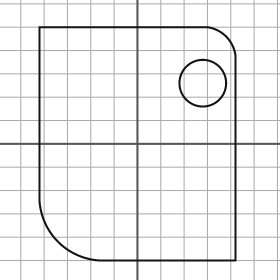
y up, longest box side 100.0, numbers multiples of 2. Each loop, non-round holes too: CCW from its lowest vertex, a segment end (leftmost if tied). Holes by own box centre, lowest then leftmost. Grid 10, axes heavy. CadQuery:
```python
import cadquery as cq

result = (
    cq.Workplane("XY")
    .moveTo(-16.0, -50.0)
    .lineTo(42.0, -50.0)
    .lineTo(42.0, 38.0)
    .threePointArc((38.0, 46.0), (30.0, 50.0))
    .lineTo(-42.0, 50.0)
    .lineTo(-42.0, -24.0)
    .threePointArc((-34.0, -42.0), (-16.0, -50.0))
    .close()
    .moveTo(28.0, 26.0)
    .circle(10.0)
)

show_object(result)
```